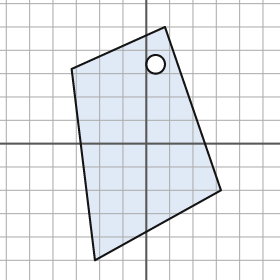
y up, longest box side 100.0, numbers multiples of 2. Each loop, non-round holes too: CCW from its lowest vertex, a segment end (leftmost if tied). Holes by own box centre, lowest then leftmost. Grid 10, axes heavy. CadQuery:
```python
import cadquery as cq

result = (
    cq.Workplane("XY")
    .moveTo(-22.0, -50.0)
    .lineTo(32.0, -20.0)
    .lineTo(8.0, 50.0)
    .lineTo(-32.0, 32.0)
    .close()
    .moveTo(4.0, 34.0)
    .circle(4.0)
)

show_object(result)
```